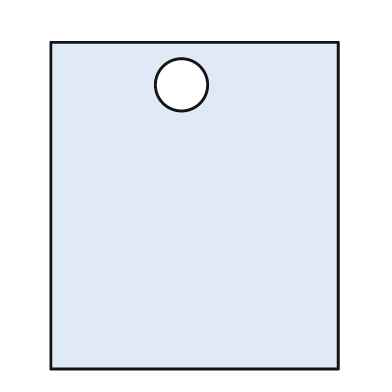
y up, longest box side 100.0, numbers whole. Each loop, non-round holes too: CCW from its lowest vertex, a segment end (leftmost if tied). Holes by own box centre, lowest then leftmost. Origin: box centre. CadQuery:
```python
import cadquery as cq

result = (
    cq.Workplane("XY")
    .moveTo(-44.0, -50.0)
    .lineTo(44.0, -50.0)
    .lineTo(44.0, 50.0)
    .lineTo(-44.0, 50.0)
    .close()
    .moveTo(-4.0, 37.0)
    .circle(8.0)
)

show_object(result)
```